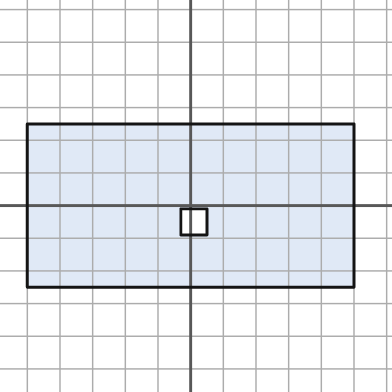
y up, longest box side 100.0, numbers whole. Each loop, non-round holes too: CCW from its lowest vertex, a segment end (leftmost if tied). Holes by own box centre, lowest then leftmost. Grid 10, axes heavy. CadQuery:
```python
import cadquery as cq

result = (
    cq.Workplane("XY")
    .moveTo(-50.0, -25.0)
    .lineTo(50.0, -25.0)
    .lineTo(50.0, 25.0)
    .lineTo(-50.0, 25.0)
    .close()
    .moveTo(-3.0, -9.0)
    .lineTo(5.0, -9.0)
    .lineTo(5.0, -1.0)
    .lineTo(-3.0, -1.0)
    .close()
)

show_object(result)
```